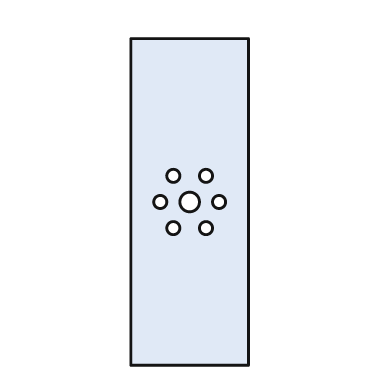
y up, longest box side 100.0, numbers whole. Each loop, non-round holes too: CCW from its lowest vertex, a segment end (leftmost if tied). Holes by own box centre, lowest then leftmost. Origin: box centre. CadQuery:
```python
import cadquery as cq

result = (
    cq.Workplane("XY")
    .moveTo(-18.0, -50.0)
    .lineTo(18.0, -50.0)
    .lineTo(18.0, 50.0)
    .lineTo(-18.0, 50.0)
    .close()
    .moveTo(-5.0, -8.0)
    .circle(2.0)
    .moveTo(5.0, -8.0)
    .circle(2.0)
    .moveTo(-9.0, 0.0)
    .circle(2.0)
    .moveTo(0.0, 0.0)
    .circle(3.0)
    .moveTo(9.0, 0.0)
    .circle(2.0)
    .moveTo(-5.0, 8.0)
    .circle(2.0)
    .moveTo(5.0, 8.0)
    .circle(2.0)
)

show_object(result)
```